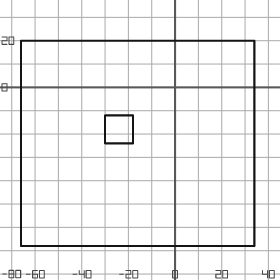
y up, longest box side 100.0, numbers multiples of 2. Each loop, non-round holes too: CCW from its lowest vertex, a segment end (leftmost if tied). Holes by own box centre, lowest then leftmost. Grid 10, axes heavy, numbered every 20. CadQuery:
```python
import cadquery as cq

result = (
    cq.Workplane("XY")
    .moveTo(-66.0, -68.0)
    .lineTo(34.0, -68.0)
    .lineTo(34.0, 20.0)
    .lineTo(-66.0, 20.0)
    .close()
    .moveTo(-30.0, -24.0)
    .lineTo(-18.0, -24.0)
    .lineTo(-18.0, -12.0)
    .lineTo(-30.0, -12.0)
    .close()
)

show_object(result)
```